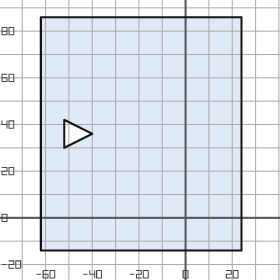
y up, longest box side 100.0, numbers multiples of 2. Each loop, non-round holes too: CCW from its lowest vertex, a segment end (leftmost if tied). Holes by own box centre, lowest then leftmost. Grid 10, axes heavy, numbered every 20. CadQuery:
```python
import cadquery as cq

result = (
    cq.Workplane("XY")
    .moveTo(-62.0, -14.0)
    .lineTo(24.0, -14.0)
    .lineTo(24.0, 86.0)
    .lineTo(-62.0, 86.0)
    .close()
    .moveTo(-52.0, 30.0)
    .lineTo(-40.0, 36.0)
    .lineTo(-52.0, 42.0)
    .close()
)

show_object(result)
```